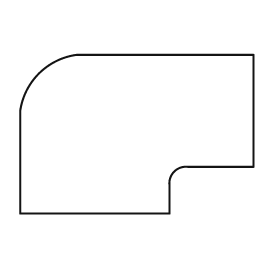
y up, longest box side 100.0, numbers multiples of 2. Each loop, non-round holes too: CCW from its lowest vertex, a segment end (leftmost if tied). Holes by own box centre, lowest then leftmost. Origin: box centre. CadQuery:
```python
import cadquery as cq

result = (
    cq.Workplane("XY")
    .moveTo(-50.0, -34.0)
    .lineTo(14.0, -34.0)
    .lineTo(14.0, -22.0)
    .threePointArc((16.0, -16.0), (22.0, -14.0))
    .lineTo(50.0, -14.0)
    .lineTo(50.0, 34.0)
    .lineTo(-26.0, 34.0)
    .threePointArc((-42.0, 26.0), (-50.0, 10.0))
    .close()
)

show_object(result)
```